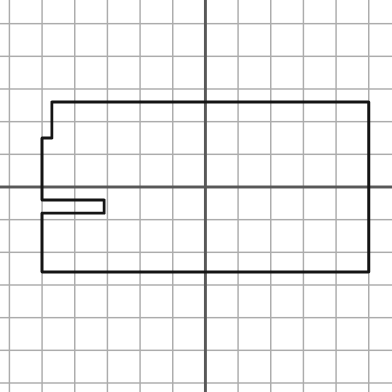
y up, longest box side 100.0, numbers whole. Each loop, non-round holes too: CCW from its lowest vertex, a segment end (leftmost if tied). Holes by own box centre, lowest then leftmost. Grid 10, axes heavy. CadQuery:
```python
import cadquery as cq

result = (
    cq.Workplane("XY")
    .moveTo(-50.0, -26.0)
    .lineTo(50.0, -26.0)
    .lineTo(50.0, 26.0)
    .lineTo(-47.0, 26.0)
    .lineTo(-47.0, 15.0)
    .lineTo(-50.0, 15.0)
    .lineTo(-50.0, -4.0)
    .lineTo(-31.0, -4.0)
    .lineTo(-31.0, -8.0)
    .lineTo(-50.0, -8.0)
    .close()
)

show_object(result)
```